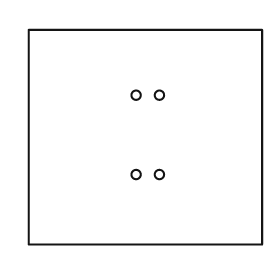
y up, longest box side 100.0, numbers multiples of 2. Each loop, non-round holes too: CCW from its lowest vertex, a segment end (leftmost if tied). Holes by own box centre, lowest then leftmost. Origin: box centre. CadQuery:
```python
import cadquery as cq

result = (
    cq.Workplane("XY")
    .moveTo(-50.0, -46.0)
    .lineTo(50.0, -46.0)
    .lineTo(50.0, 46.0)
    .lineTo(-50.0, 46.0)
    .close()
    .moveTo(-4.0, -16.0)
    .circle(2.0)
    .moveTo(6.0, -16.0)
    .circle(2.0)
    .moveTo(-4.0, 18.0)
    .circle(2.0)
    .moveTo(6.0, 18.0)
    .circle(2.0)
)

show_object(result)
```